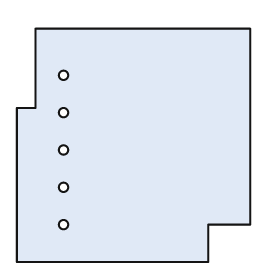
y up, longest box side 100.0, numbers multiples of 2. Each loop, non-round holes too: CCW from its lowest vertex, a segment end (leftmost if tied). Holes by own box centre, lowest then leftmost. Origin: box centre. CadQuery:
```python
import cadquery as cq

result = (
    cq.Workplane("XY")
    .moveTo(-50.0, -50.0)
    .lineTo(32.0, -50.0)
    .lineTo(32.0, -34.0)
    .lineTo(50.0, -34.0)
    .lineTo(50.0, 50.0)
    .lineTo(-42.0, 50.0)
    .lineTo(-42.0, 16.0)
    .lineTo(-50.0, 16.0)
    .close()
    .moveTo(-30.0, -34.0)
    .circle(2.0)
    .moveTo(-30.0, -18.0)
    .circle(2.0)
    .moveTo(-30.0, -2.0)
    .circle(2.0)
    .moveTo(-30.0, 14.0)
    .circle(2.0)
    .moveTo(-30.0, 30.0)
    .circle(2.0)
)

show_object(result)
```